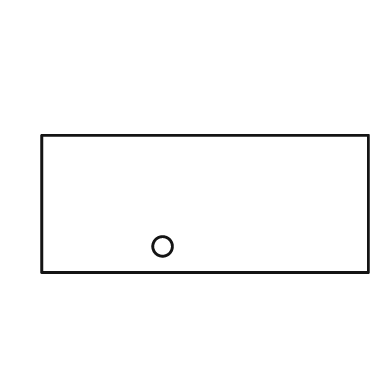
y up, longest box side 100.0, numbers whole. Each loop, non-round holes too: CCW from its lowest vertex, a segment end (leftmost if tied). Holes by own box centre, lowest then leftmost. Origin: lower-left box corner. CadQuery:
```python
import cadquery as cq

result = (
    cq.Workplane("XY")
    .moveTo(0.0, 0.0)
    .lineTo(100.0, 0.0)
    .lineTo(100.0, 42.0)
    .lineTo(0.0, 42.0)
    .close()
    .moveTo(37.0, 8.0)
    .circle(3.0)
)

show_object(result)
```